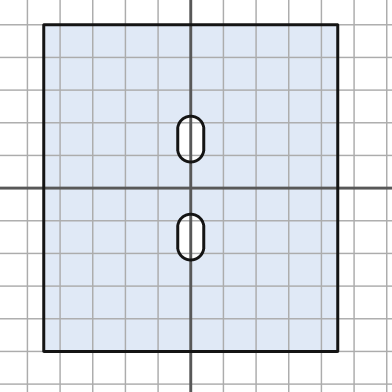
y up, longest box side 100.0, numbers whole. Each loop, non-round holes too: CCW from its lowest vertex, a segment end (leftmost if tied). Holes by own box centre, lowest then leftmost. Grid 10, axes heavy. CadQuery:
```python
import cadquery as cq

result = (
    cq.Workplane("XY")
    .moveTo(-45.0, -50.0)
    .lineTo(45.0, -50.0)
    .lineTo(45.0, 50.0)
    .lineTo(-45.0, 50.0)
    .close()
    .moveTo(-4.0, -18.0)
    .threePointArc((0.0, -22.0), (4.0, -18.0))
    .lineTo(4.0, -12.0)
    .threePointArc((0.0, -8.0), (-4.0, -12.0))
    .close()
    .moveTo(-4.0, 12.0)
    .threePointArc((0.0, 8.0), (4.0, 12.0))
    .lineTo(4.0, 18.0)
    .threePointArc((0.0, 22.0), (-4.0, 18.0))
    .close()
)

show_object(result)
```